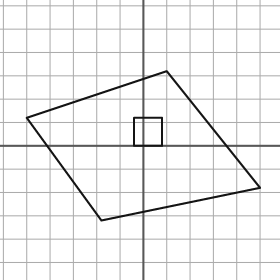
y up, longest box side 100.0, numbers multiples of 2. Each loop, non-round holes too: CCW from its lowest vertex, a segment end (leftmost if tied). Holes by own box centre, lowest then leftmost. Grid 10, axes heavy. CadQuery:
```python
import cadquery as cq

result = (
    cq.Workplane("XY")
    .moveTo(-18.0, -32.0)
    .lineTo(50.0, -18.0)
    .lineTo(10.0, 32.0)
    .lineTo(-50.0, 12.0)
    .close()
    .moveTo(-4.0, 0.0)
    .lineTo(8.0, 0.0)
    .lineTo(8.0, 12.0)
    .lineTo(-4.0, 12.0)
    .close()
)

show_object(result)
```